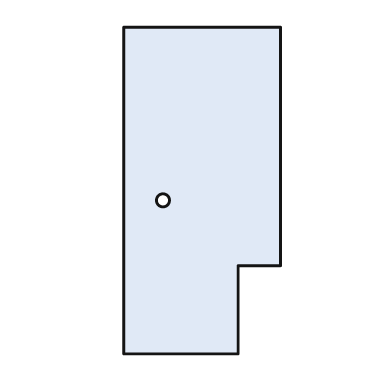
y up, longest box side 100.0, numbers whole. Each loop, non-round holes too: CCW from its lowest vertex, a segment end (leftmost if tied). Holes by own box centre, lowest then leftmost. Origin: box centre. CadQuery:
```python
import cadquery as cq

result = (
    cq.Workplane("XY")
    .moveTo(-24.0, -50.0)
    .lineTo(11.0, -50.0)
    .lineTo(11.0, -23.0)
    .lineTo(24.0, -23.0)
    .lineTo(24.0, 50.0)
    .lineTo(-24.0, 50.0)
    .close()
    .moveTo(-12.0, -3.0)
    .circle(2.0)
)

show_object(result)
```